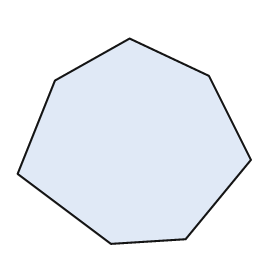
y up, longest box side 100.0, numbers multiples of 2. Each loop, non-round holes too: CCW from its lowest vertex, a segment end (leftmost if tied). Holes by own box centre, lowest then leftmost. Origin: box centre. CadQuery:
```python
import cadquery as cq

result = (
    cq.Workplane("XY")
    .moveTo(-10.0, -44.0)
    .lineTo(22.0, -42.0)
    .lineTo(50.0, -8.0)
    .lineTo(32.0, 28.0)
    .lineTo(-2.0, 44.0)
    .lineTo(-34.0, 26.0)
    .lineTo(-50.0, -14.0)
    .close()
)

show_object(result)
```